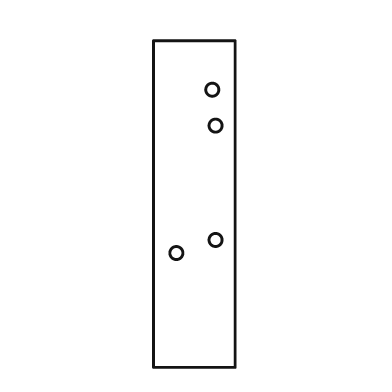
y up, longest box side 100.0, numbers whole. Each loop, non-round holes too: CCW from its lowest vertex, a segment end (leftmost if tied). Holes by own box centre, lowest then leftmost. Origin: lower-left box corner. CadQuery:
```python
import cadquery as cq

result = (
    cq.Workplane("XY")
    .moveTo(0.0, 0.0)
    .lineTo(25.0, 0.0)
    .lineTo(25.0, 100.0)
    .lineTo(0.0, 100.0)
    .close()
    .moveTo(7.0, 35.0)
    .circle(2.0)
    .moveTo(19.0, 39.0)
    .circle(2.0)
    .moveTo(19.0, 74.0)
    .circle(2.0)
    .moveTo(18.0, 85.0)
    .circle(2.0)
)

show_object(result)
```